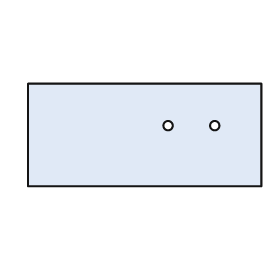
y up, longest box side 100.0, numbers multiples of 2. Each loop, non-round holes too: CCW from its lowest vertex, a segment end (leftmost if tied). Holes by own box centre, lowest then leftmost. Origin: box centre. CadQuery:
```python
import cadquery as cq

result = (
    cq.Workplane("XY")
    .moveTo(-50.0, -22.0)
    .lineTo(50.0, -22.0)
    .lineTo(50.0, 22.0)
    .lineTo(-50.0, 22.0)
    .close()
    .moveTo(10.0, 4.0)
    .circle(2.0)
    .moveTo(30.0, 4.0)
    .circle(2.0)
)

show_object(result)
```